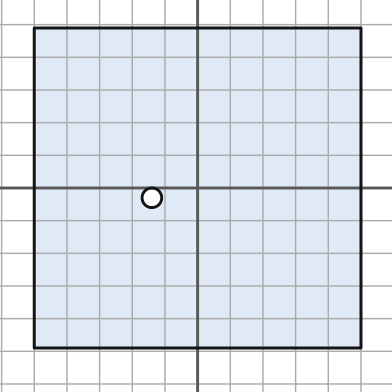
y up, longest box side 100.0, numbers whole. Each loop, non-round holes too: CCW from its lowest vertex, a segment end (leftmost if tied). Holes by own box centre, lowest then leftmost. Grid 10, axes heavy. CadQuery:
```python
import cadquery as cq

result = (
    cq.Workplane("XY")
    .moveTo(-50.0, -49.0)
    .lineTo(50.0, -49.0)
    .lineTo(50.0, 49.0)
    .lineTo(-50.0, 49.0)
    .close()
    .moveTo(-14.0, -3.0)
    .circle(3.0)
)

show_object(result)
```